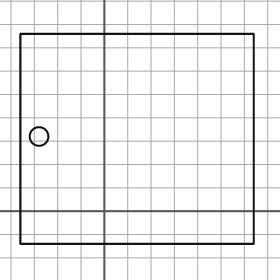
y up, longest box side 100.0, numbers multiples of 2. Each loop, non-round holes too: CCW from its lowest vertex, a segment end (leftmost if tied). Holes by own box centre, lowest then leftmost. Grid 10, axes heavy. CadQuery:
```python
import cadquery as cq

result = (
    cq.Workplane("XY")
    .moveTo(-36.0, -14.0)
    .lineTo(64.0, -14.0)
    .lineTo(64.0, 76.0)
    .lineTo(-36.0, 76.0)
    .close()
    .moveTo(-28.0, 32.0)
    .circle(4.0)
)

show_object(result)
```